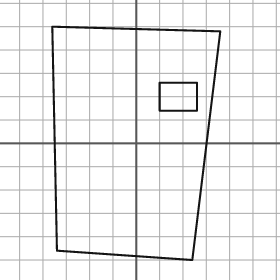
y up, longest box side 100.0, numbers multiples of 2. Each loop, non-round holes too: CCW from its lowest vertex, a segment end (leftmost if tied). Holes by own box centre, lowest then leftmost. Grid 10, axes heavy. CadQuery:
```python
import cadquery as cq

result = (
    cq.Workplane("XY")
    .moveTo(24.0, -50.0)
    .lineTo(36.0, 48.0)
    .lineTo(-36.0, 50.0)
    .lineTo(-34.0, -46.0)
    .close()
    .moveTo(10.0, 14.0)
    .lineTo(26.0, 14.0)
    .lineTo(26.0, 26.0)
    .lineTo(10.0, 26.0)
    .close()
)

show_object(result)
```